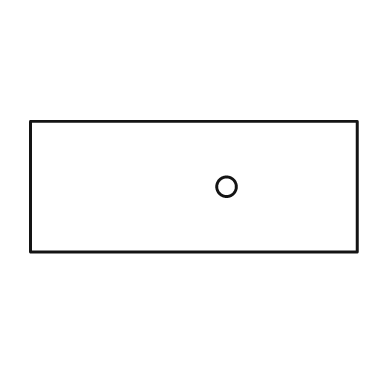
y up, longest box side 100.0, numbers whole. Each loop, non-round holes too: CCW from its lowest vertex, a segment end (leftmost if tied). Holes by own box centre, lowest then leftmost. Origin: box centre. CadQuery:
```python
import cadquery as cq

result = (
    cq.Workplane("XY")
    .moveTo(-50.0, -20.0)
    .lineTo(50.0, -20.0)
    .lineTo(50.0, 20.0)
    .lineTo(-50.0, 20.0)
    .close()
    .moveTo(10.0, 0.0)
    .circle(3.0)
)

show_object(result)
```